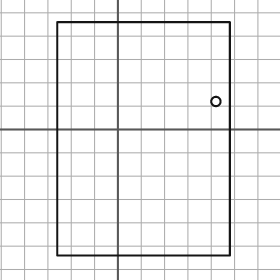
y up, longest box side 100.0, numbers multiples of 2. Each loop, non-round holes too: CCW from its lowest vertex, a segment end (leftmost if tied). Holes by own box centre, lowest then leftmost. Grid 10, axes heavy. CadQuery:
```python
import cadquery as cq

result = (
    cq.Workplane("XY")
    .moveTo(-26.0, -54.0)
    .lineTo(48.0, -54.0)
    .lineTo(48.0, 46.0)
    .lineTo(-26.0, 46.0)
    .close()
    .moveTo(42.0, 12.0)
    .circle(2.0)
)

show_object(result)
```